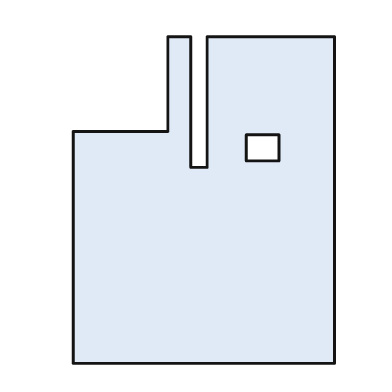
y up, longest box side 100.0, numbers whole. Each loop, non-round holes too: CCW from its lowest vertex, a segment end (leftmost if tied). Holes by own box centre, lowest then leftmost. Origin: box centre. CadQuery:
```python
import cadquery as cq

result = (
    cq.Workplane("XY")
    .moveTo(-40.0, -50.0)
    .lineTo(40.0, -50.0)
    .lineTo(40.0, 50.0)
    .lineTo(1.0, 50.0)
    .lineTo(1.0, 10.0)
    .lineTo(-4.0, 10.0)
    .lineTo(-4.0, 50.0)
    .lineTo(-11.0, 50.0)
    .lineTo(-11.0, 21.0)
    .lineTo(-40.0, 21.0)
    .close()
    .moveTo(13.0, 12.0)
    .lineTo(23.0, 12.0)
    .lineTo(23.0, 20.0)
    .lineTo(13.0, 20.0)
    .close()
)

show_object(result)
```